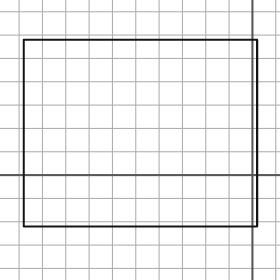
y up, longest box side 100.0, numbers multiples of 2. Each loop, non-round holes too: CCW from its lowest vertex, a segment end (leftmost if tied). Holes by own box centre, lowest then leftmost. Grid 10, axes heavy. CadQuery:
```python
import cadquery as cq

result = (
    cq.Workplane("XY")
    .moveTo(-98.0, -22.0)
    .lineTo(2.0, -22.0)
    .lineTo(2.0, 58.0)
    .lineTo(-98.0, 58.0)
    .close()
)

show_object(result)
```